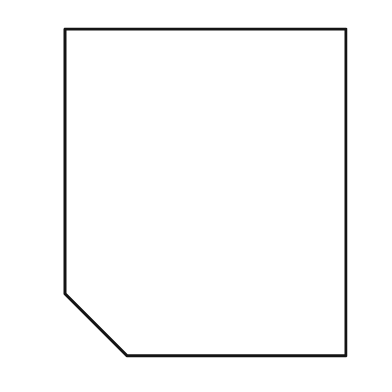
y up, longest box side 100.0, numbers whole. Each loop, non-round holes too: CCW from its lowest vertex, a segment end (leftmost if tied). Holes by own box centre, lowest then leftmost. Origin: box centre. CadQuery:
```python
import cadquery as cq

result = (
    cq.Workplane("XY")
    .moveTo(-24.0, -50.0)
    .lineTo(43.0, -50.0)
    .lineTo(43.0, 50.0)
    .lineTo(-43.0, 50.0)
    .lineTo(-43.0, -31.0)
    .close()
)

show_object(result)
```